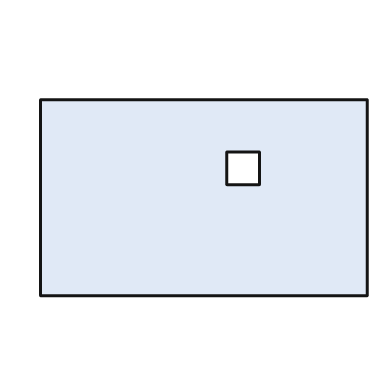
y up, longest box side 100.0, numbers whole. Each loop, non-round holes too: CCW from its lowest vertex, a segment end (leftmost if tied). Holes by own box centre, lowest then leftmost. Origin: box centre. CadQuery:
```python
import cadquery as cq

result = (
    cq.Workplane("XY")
    .moveTo(-50.0, -30.0)
    .lineTo(50.0, -30.0)
    .lineTo(50.0, 30.0)
    .lineTo(-50.0, 30.0)
    .close()
    .moveTo(7.0, 4.0)
    .lineTo(17.0, 4.0)
    .lineTo(17.0, 14.0)
    .lineTo(7.0, 14.0)
    .close()
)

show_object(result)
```